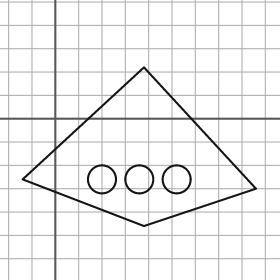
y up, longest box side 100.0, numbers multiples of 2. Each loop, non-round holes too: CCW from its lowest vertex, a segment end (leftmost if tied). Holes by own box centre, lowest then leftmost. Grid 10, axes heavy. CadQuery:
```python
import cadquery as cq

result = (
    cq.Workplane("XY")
    .moveTo(38.0, -46.0)
    .lineTo(86.0, -30.0)
    .lineTo(38.0, 22.0)
    .lineTo(-14.0, -26.0)
    .close()
    .moveTo(20.0, -26.0)
    .circle(6.0)
    .moveTo(36.0, -26.0)
    .circle(6.0)
    .moveTo(52.0, -26.0)
    .circle(6.0)
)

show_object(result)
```